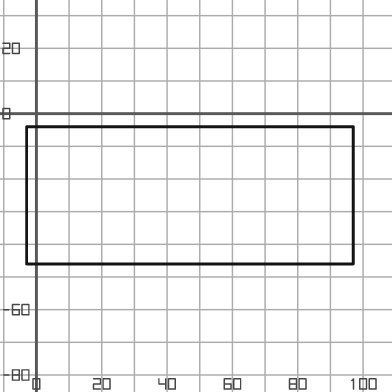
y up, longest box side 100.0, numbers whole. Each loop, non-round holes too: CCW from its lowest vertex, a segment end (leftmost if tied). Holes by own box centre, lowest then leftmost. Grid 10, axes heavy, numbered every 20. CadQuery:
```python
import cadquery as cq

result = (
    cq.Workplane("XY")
    .moveTo(-3.0, -46.0)
    .lineTo(97.0, -46.0)
    .lineTo(97.0, -4.0)
    .lineTo(-3.0, -4.0)
    .close()
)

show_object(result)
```